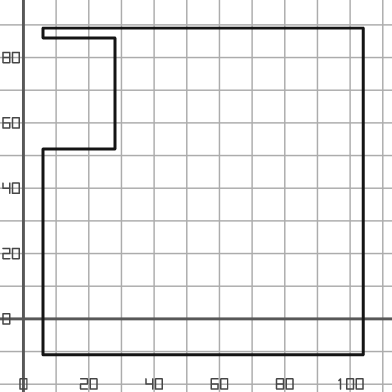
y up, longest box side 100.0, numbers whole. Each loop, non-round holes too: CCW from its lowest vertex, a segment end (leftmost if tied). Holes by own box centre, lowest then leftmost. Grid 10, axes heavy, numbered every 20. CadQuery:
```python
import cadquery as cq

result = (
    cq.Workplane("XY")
    .moveTo(6.0, -11.0)
    .lineTo(104.0, -11.0)
    .lineTo(104.0, 89.0)
    .lineTo(6.0, 89.0)
    .lineTo(6.0, 86.0)
    .lineTo(28.0, 86.0)
    .lineTo(28.0, 52.0)
    .lineTo(6.0, 52.0)
    .close()
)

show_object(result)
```